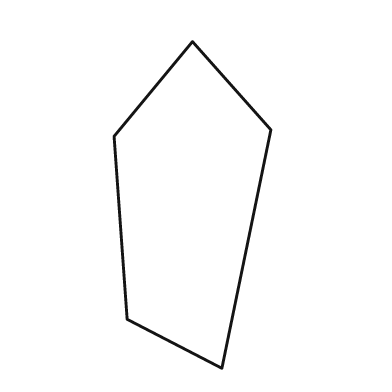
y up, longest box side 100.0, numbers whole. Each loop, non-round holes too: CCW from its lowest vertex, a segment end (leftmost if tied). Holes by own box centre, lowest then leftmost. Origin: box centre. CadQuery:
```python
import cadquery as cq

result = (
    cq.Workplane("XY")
    .moveTo(9.0, -50.0)
    .lineTo(24.0, 23.0)
    .lineTo(0.0, 50.0)
    .lineTo(-24.0, 21.0)
    .lineTo(-20.0, -35.0)
    .close()
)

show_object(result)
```